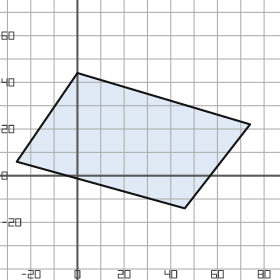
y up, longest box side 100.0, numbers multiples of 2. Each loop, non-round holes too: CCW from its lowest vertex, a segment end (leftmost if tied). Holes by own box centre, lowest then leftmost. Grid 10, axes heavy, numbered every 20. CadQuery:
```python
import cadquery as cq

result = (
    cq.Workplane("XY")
    .moveTo(46.0, -14.0)
    .lineTo(74.0, 22.0)
    .lineTo(0.0, 44.0)
    .lineTo(-26.0, 6.0)
    .close()
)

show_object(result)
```